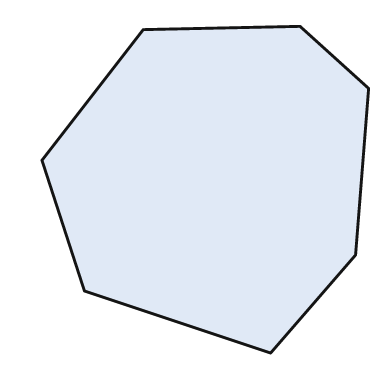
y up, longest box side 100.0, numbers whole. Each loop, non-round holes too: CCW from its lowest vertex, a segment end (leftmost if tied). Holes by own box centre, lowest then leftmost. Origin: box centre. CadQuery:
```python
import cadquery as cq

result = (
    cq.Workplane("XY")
    .moveTo(20.0, -50.0)
    .lineTo(46.0, -20.0)
    .lineTo(50.0, 31.0)
    .lineTo(29.0, 50.0)
    .lineTo(-19.0, 49.0)
    .lineTo(-50.0, 9.0)
    .lineTo(-37.0, -31.0)
    .close()
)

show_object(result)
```